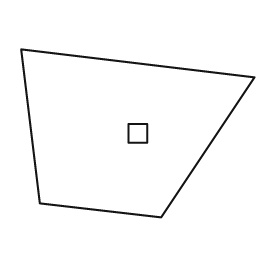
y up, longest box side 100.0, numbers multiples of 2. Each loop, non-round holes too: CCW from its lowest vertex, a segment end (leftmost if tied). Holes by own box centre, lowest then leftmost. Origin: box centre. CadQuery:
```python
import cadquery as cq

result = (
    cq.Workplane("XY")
    .moveTo(10.0, -36.0)
    .lineTo(50.0, 24.0)
    .lineTo(-50.0, 36.0)
    .lineTo(-42.0, -30.0)
    .close()
    .moveTo(-4.0, -4.0)
    .lineTo(4.0, -4.0)
    .lineTo(4.0, 4.0)
    .lineTo(-4.0, 4.0)
    .close()
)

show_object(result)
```